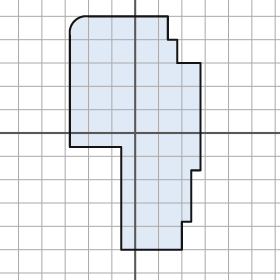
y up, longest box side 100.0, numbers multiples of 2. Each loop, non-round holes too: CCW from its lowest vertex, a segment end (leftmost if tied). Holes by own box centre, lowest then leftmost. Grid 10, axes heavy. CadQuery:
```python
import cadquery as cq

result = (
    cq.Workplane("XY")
    .moveTo(-6.0, -50.0)
    .lineTo(20.0, -50.0)
    .lineTo(20.0, -38.0)
    .lineTo(24.0, -38.0)
    .lineTo(24.0, -16.0)
    .lineTo(28.0, -16.0)
    .lineTo(28.0, 30.0)
    .lineTo(18.0, 30.0)
    .lineTo(18.0, 40.0)
    .lineTo(14.0, 40.0)
    .lineTo(14.0, 50.0)
    .lineTo(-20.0, 50.0)
    .threePointArc((-26.0, 48.0), (-28.0, 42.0))
    .lineTo(-28.0, -6.0)
    .lineTo(-6.0, -6.0)
    .close()
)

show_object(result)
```